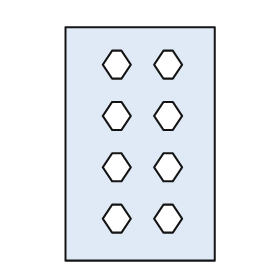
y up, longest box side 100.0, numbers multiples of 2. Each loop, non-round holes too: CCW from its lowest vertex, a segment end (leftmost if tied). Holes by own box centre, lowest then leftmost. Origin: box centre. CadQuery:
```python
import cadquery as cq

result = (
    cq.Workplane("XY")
    .moveTo(-32.0, -50.0)
    .lineTo(32.0, -50.0)
    .lineTo(32.0, 50.0)
    .lineTo(-32.0, 50.0)
    .close()
    .moveTo(-12.0, -38.0)
    .lineTo(-8.0, -38.0)
    .lineTo(-4.0, -32.0)
    .lineTo(-8.0, -26.0)
    .lineTo(-12.0, -26.0)
    .lineTo(-16.0, -32.0)
    .close()
    .moveTo(10.0, -38.0)
    .lineTo(14.0, -38.0)
    .lineTo(18.0, -32.0)
    .lineTo(14.0, -26.0)
    .lineTo(10.0, -26.0)
    .lineTo(6.0, -32.0)
    .close()
    .moveTo(-12.0, -16.0)
    .lineTo(-8.0, -16.0)
    .lineTo(-4.0, -10.0)
    .lineTo(-8.0, -4.0)
    .lineTo(-12.0, -4.0)
    .lineTo(-16.0, -10.0)
    .close()
    .moveTo(10.0, -16.0)
    .lineTo(14.0, -16.0)
    .lineTo(18.0, -10.0)
    .lineTo(14.0, -4.0)
    .lineTo(10.0, -4.0)
    .lineTo(6.0, -10.0)
    .close()
    .moveTo(-12.0, 6.0)
    .lineTo(-8.0, 6.0)
    .lineTo(-4.0, 12.0)
    .lineTo(-8.0, 18.0)
    .lineTo(-12.0, 18.0)
    .lineTo(-16.0, 12.0)
    .close()
    .moveTo(10.0, 6.0)
    .lineTo(14.0, 6.0)
    .lineTo(18.0, 12.0)
    .lineTo(14.0, 18.0)
    .lineTo(10.0, 18.0)
    .lineTo(6.0, 12.0)
    .close()
    .moveTo(-12.0, 28.0)
    .lineTo(-8.0, 28.0)
    .lineTo(-4.0, 34.0)
    .lineTo(-8.0, 40.0)
    .lineTo(-12.0, 40.0)
    .lineTo(-16.0, 34.0)
    .close()
    .moveTo(10.0, 28.0)
    .lineTo(14.0, 28.0)
    .lineTo(18.0, 34.0)
    .lineTo(14.0, 40.0)
    .lineTo(10.0, 40.0)
    .lineTo(6.0, 34.0)
    .close()
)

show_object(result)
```